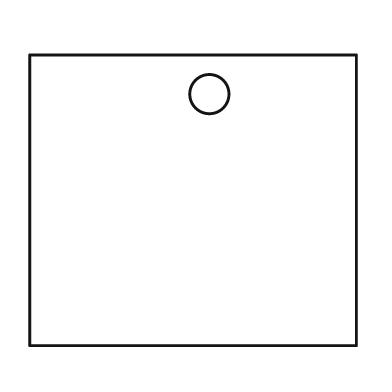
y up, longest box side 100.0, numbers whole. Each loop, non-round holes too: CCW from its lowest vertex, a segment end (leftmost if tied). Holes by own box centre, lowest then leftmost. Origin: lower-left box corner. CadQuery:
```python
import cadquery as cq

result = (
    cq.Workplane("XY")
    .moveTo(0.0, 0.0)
    .lineTo(100.0, 0.0)
    .lineTo(100.0, 89.0)
    .lineTo(0.0, 89.0)
    .close()
    .moveTo(55.0, 77.0)
    .circle(6.0)
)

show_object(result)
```